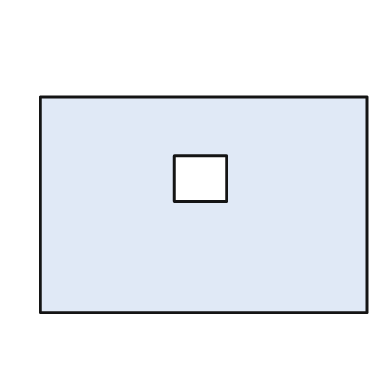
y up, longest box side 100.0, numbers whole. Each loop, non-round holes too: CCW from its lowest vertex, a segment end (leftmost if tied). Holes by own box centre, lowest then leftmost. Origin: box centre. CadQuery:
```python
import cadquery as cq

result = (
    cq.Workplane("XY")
    .moveTo(-50.0, -33.0)
    .lineTo(50.0, -33.0)
    .lineTo(50.0, 33.0)
    .lineTo(-50.0, 33.0)
    .close()
    .moveTo(-9.0, 1.0)
    .lineTo(7.0, 1.0)
    .lineTo(7.0, 15.0)
    .lineTo(-9.0, 15.0)
    .close()
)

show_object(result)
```